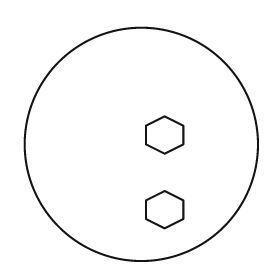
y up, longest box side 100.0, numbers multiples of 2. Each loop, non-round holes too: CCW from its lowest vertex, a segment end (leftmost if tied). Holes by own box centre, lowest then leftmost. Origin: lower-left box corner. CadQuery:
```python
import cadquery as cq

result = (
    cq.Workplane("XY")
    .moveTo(50.0, 50.0)
    .circle(50.0)
    .moveTo(60.0, 14.0)
    .lineTo(68.0, 18.0)
    .lineTo(68.0, 26.0)
    .lineTo(60.0, 30.0)
    .lineTo(52.0, 26.0)
    .lineTo(52.0, 18.0)
    .close()
    .moveTo(60.0, 46.0)
    .lineTo(68.0, 50.0)
    .lineTo(68.0, 58.0)
    .lineTo(60.0, 62.0)
    .lineTo(52.0, 58.0)
    .lineTo(52.0, 50.0)
    .close()
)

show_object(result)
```